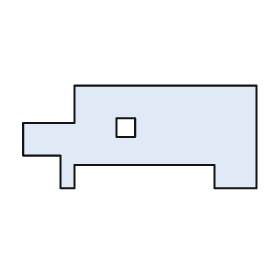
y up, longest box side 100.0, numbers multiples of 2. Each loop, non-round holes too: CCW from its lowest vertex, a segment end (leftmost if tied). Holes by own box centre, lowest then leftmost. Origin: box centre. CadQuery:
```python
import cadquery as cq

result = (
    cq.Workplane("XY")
    .moveTo(-34.0, -22.0)
    .lineTo(-28.0, -22.0)
    .lineTo(-28.0, -12.0)
    .lineTo(32.0, -12.0)
    .lineTo(32.0, -22.0)
    .lineTo(50.0, -22.0)
    .lineTo(50.0, 22.0)
    .lineTo(-28.0, 22.0)
    .lineTo(-28.0, 6.0)
    .lineTo(-50.0, 6.0)
    .lineTo(-50.0, -8.0)
    .lineTo(-34.0, -8.0)
    .close()
    .moveTo(-10.0, 0.0)
    .lineTo(-2.0, 0.0)
    .lineTo(-2.0, 8.0)
    .lineTo(-10.0, 8.0)
    .close()
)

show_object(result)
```